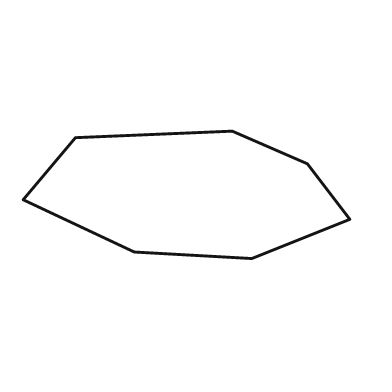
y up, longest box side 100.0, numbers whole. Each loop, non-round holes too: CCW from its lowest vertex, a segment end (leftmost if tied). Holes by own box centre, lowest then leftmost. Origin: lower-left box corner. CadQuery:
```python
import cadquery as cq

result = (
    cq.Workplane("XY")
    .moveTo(70.0, 0.0)
    .lineTo(100.0, 12.0)
    .lineTo(87.0, 29.0)
    .lineTo(64.0, 39.0)
    .lineTo(16.0, 37.0)
    .lineTo(0.0, 18.0)
    .lineTo(34.0, 2.0)
    .close()
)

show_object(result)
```